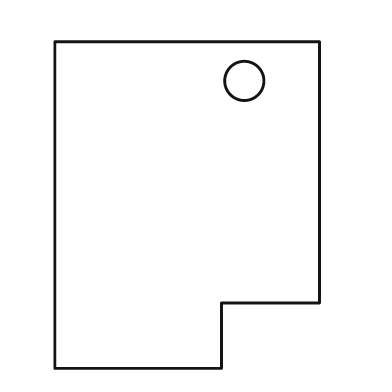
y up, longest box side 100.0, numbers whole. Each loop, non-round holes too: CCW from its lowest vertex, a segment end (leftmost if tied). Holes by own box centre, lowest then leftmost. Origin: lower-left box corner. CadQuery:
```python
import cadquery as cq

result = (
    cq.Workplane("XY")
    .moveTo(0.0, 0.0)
    .lineTo(51.0, 0.0)
    .lineTo(51.0, 20.0)
    .lineTo(81.0, 20.0)
    .lineTo(81.0, 100.0)
    .lineTo(0.0, 100.0)
    .close()
    .moveTo(58.0, 88.0)
    .circle(6.0)
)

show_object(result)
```